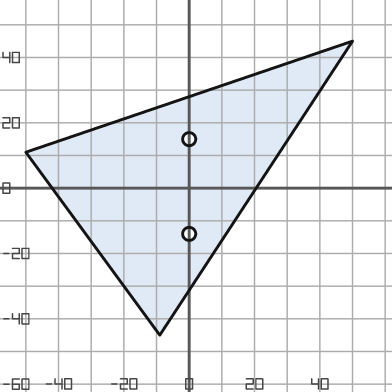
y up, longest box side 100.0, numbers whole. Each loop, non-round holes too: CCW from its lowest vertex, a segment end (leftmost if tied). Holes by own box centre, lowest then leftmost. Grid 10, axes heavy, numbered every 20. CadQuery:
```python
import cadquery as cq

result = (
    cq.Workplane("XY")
    .moveTo(-9.0, -45.0)
    .lineTo(50.0, 45.0)
    .lineTo(-50.0, 11.0)
    .close()
    .moveTo(0.0, -14.0)
    .circle(2.0)
    .moveTo(0.0, 15.0)
    .circle(2.0)
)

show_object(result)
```